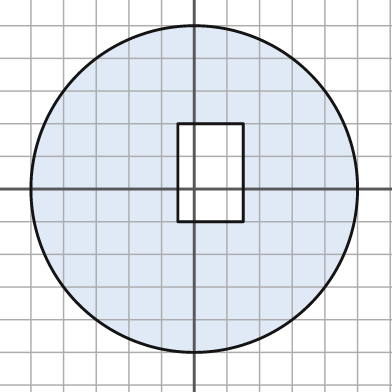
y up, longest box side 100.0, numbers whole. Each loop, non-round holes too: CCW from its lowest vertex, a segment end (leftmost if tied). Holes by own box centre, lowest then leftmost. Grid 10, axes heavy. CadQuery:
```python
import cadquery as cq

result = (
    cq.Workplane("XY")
    .moveTo(0.0, 0.0)
    .circle(50.0)
    .moveTo(-5.0, -10.0)
    .lineTo(15.0, -10.0)
    .lineTo(15.0, 20.0)
    .lineTo(-5.0, 20.0)
    .close()
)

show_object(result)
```